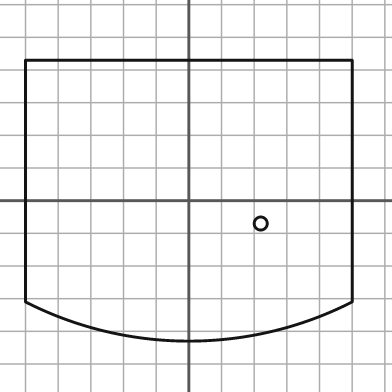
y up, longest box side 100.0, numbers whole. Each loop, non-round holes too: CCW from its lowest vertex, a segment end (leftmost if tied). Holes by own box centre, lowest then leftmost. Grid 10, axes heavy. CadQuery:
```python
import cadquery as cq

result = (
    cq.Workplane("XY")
    .moveTo(-50.0, -31.0)
    .threePointArc((0.0, -43.0), (50.0, -31.0))
    .lineTo(50.0, 43.0)
    .lineTo(-50.0, 43.0)
    .close()
    .moveTo(22.0, -7.0)
    .circle(2.0)
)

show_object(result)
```